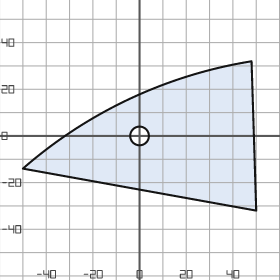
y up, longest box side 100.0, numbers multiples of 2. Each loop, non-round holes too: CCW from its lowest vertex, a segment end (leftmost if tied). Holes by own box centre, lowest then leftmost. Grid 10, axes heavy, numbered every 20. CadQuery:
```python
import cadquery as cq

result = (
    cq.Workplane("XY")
    .moveTo(50.0, -32.0)
    .lineTo(48.0, 32.0)
    .threePointArc((-4.0, 16.0), (-50.0, -14.0))
    .close()
    .moveTo(0.0, 0.0)
    .circle(4.0)
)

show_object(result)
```